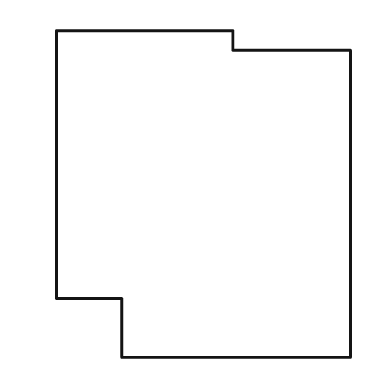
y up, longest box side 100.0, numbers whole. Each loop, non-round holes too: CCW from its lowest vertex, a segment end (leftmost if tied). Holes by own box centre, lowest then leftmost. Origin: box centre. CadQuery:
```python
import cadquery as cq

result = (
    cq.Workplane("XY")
    .moveTo(-25.0, -50.0)
    .lineTo(45.0, -50.0)
    .lineTo(45.0, 44.0)
    .lineTo(9.0, 44.0)
    .lineTo(9.0, 50.0)
    .lineTo(-45.0, 50.0)
    .lineTo(-45.0, -32.0)
    .lineTo(-25.0, -32.0)
    .close()
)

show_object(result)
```